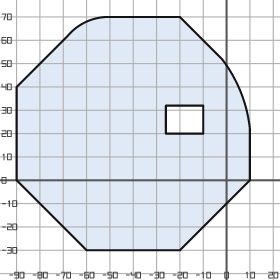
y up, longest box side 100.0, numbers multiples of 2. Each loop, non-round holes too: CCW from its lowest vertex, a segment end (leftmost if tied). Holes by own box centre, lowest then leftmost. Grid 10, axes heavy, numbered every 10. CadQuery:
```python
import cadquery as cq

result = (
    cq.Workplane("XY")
    .moveTo(-60.0, -30.0)
    .lineTo(-20.0, -30.0)
    .lineTo(10.0, 0.0)
    .lineTo(10.0, 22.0)
    .threePointArc((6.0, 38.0), (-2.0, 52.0))
    .lineTo(-20.0, 70.0)
    .lineTo(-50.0, 70.0)
    .threePointArc((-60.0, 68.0), (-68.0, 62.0))
    .lineTo(-90.0, 40.0)
    .lineTo(-90.0, 0.0)
    .close()
    .moveTo(-26.0, 20.0)
    .lineTo(-10.0, 20.0)
    .lineTo(-10.0, 32.0)
    .lineTo(-26.0, 32.0)
    .close()
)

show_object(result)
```